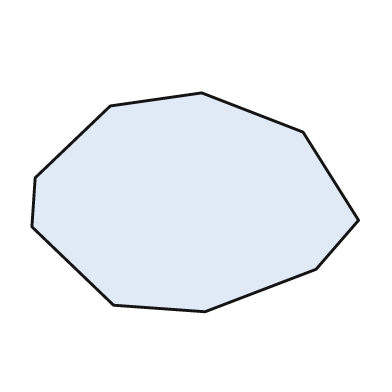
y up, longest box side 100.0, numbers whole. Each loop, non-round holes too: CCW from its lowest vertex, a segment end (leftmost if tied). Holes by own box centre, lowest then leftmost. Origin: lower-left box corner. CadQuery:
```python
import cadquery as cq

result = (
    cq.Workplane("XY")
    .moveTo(53.0, 0.0)
    .lineTo(87.0, 13.0)
    .lineTo(100.0, 28.0)
    .lineTo(83.0, 55.0)
    .lineTo(52.0, 67.0)
    .lineTo(24.0, 63.0)
    .lineTo(1.0, 41.0)
    .lineTo(0.0, 26.0)
    .lineTo(25.0, 2.0)
    .close()
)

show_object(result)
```